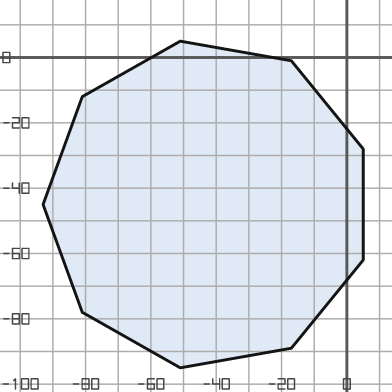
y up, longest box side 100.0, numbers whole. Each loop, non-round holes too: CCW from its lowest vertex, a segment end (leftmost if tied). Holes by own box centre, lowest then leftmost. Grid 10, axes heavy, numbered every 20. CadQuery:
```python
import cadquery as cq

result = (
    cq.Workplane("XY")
    .moveTo(-51.0, -95.0)
    .lineTo(-17.0, -89.0)
    .lineTo(5.0, -62.0)
    .lineTo(5.0, -28.0)
    .lineTo(-17.0, -1.0)
    .lineTo(-51.0, 5.0)
    .lineTo(-81.0, -12.0)
    .lineTo(-93.0, -45.0)
    .lineTo(-81.0, -78.0)
    .close()
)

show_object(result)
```